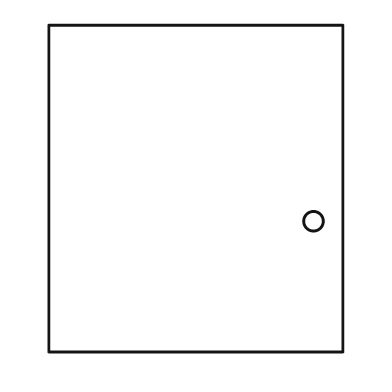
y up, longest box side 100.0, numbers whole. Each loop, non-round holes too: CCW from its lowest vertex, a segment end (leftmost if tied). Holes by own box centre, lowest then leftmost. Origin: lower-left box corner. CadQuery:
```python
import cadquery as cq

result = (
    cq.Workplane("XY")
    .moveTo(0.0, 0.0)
    .lineTo(90.0, 0.0)
    .lineTo(90.0, 100.0)
    .lineTo(0.0, 100.0)
    .close()
    .moveTo(81.0, 40.0)
    .circle(3.0)
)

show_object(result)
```